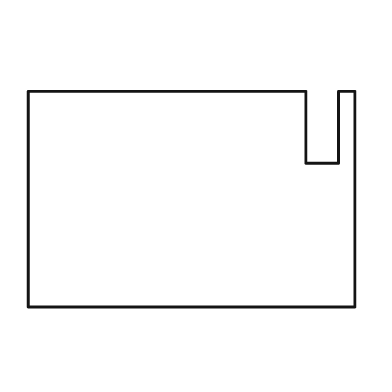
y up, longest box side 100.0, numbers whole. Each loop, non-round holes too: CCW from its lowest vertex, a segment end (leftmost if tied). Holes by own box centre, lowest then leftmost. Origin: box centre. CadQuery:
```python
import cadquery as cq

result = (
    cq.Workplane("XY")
    .moveTo(-50.0, -33.0)
    .lineTo(50.0, -33.0)
    .lineTo(50.0, 33.0)
    .lineTo(45.0, 33.0)
    .lineTo(45.0, 11.0)
    .lineTo(35.0, 11.0)
    .lineTo(35.0, 33.0)
    .lineTo(-50.0, 33.0)
    .close()
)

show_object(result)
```